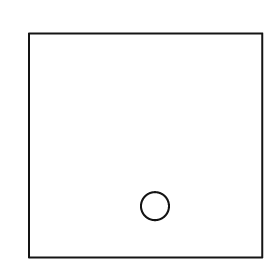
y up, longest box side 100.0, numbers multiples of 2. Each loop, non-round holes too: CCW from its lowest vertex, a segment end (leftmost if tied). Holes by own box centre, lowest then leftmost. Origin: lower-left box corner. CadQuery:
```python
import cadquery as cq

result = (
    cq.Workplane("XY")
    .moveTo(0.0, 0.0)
    .lineTo(100.0, 0.0)
    .lineTo(100.0, 96.0)
    .lineTo(0.0, 96.0)
    .close()
    .moveTo(54.0, 22.0)
    .circle(6.0)
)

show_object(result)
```